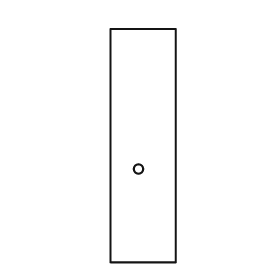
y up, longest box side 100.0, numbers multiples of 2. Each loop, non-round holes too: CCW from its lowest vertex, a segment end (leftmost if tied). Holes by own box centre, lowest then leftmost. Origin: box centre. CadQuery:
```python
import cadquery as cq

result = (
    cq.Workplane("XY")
    .moveTo(-14.0, -50.0)
    .lineTo(14.0, -50.0)
    .lineTo(14.0, 50.0)
    .lineTo(-14.0, 50.0)
    .close()
    .moveTo(-2.0, -10.0)
    .circle(2.0)
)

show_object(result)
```